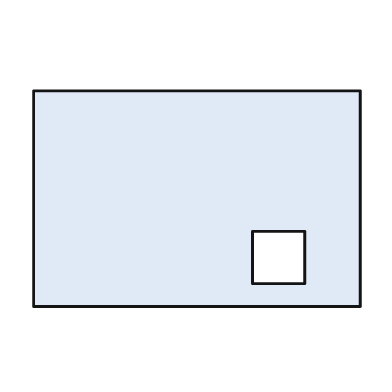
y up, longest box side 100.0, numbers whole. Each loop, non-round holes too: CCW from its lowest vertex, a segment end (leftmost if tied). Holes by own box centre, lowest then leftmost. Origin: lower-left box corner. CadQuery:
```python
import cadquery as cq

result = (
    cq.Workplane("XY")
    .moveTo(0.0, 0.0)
    .lineTo(100.0, 0.0)
    .lineTo(100.0, 66.0)
    .lineTo(0.0, 66.0)
    .close()
    .moveTo(67.0, 7.0)
    .lineTo(83.0, 7.0)
    .lineTo(83.0, 23.0)
    .lineTo(67.0, 23.0)
    .close()
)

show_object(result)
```